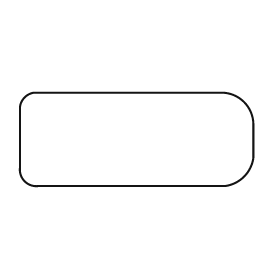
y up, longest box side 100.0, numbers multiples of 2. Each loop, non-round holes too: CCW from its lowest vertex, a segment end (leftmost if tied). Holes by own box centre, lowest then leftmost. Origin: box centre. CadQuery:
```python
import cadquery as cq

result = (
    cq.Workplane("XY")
    .moveTo(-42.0, -20.0)
    .lineTo(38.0, -20.0)
    .threePointArc((46.0, -16.0), (50.0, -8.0))
    .lineTo(50.0, 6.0)
    .threePointArc((46.0, 16.0), (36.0, 20.0))
    .lineTo(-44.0, 20.0)
    .threePointArc((-48.0, 18.0), (-50.0, 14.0))
    .lineTo(-50.0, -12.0)
    .threePointArc((-48.0, -18.0), (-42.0, -20.0))
    .close()
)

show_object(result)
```